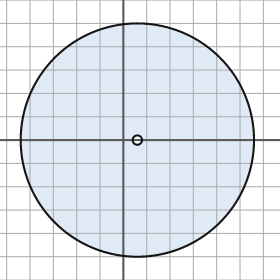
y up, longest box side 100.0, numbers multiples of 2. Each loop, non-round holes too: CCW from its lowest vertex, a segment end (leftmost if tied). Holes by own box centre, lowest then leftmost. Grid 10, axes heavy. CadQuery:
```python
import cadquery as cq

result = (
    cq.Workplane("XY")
    .moveTo(6.0, 0.0)
    .circle(50.0)
    .moveTo(6.0, 0.0)
    .circle(2.0)
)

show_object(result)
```